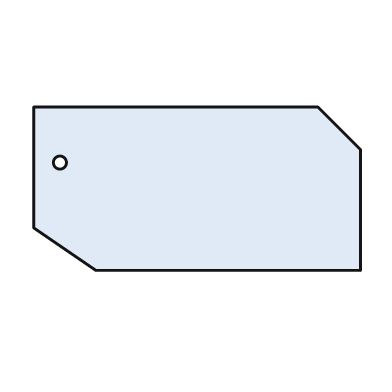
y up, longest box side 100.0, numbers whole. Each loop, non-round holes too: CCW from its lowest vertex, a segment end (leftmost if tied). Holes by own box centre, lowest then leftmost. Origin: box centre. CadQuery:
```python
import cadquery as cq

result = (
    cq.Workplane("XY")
    .moveTo(-31.0, -25.0)
    .lineTo(50.0, -25.0)
    .lineTo(50.0, 12.0)
    .lineTo(37.0, 25.0)
    .lineTo(-50.0, 25.0)
    .lineTo(-50.0, -12.0)
    .close()
    .moveTo(-42.0, 8.0)
    .circle(2.0)
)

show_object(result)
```